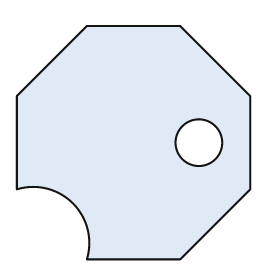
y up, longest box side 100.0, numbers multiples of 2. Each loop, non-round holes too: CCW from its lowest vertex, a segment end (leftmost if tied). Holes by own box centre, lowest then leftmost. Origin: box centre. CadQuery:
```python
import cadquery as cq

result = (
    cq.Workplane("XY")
    .moveTo(-20.0, -50.0)
    .lineTo(20.0, -50.0)
    .lineTo(50.0, -20.0)
    .lineTo(50.0, 20.0)
    .lineTo(20.0, 50.0)
    .lineTo(-20.0, 50.0)
    .lineTo(-50.0, 20.0)
    .lineTo(-50.0, -20.0)
    .threePointArc((-26.0, -26.0), (-20.0, -50.0))
    .close()
    .moveTo(28.0, 0.0)
    .circle(10.0)
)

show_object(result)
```